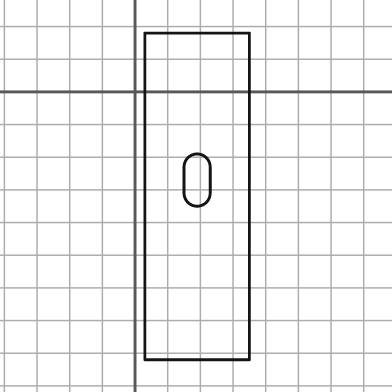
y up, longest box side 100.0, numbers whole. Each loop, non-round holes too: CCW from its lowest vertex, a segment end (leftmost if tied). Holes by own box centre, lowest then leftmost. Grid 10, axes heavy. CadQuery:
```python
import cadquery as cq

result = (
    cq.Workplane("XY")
    .moveTo(3.0, -82.0)
    .lineTo(35.0, -82.0)
    .lineTo(35.0, 18.0)
    .lineTo(3.0, 18.0)
    .close()
    .moveTo(15.0, -31.0)
    .threePointArc((19.0, -35.0), (23.0, -31.0))
    .lineTo(23.0, -23.0)
    .threePointArc((19.0, -19.0), (15.0, -23.0))
    .close()
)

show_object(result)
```